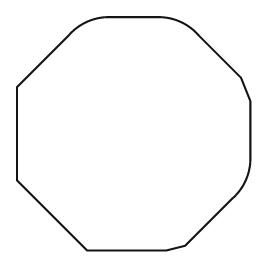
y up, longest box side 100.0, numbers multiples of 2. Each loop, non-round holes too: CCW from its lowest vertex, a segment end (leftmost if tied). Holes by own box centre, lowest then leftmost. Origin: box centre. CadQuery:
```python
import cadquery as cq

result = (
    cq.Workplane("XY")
    .moveTo(-20.0, -50.0)
    .lineTo(14.0, -50.0)
    .lineTo(22.0, -48.0)
    .lineTo(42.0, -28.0)
    .threePointArc((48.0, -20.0), (50.0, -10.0))
    .lineTo(50.0, 14.0)
    .lineTo(46.0, 24.0)
    .lineTo(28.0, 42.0)
    .threePointArc((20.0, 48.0), (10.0, 50.0))
    .lineTo(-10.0, 50.0)
    .threePointArc((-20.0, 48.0), (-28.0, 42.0))
    .lineTo(-50.0, 20.0)
    .lineTo(-50.0, -20.0)
    .close()
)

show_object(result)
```